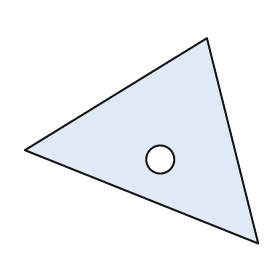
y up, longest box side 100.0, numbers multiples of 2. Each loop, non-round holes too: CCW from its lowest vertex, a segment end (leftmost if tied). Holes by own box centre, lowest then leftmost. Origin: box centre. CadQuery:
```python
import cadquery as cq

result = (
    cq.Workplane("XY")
    .moveTo(50.0, -44.0)
    .lineTo(28.0, 44.0)
    .lineTo(-50.0, -4.0)
    .close()
    .moveTo(8.0, -8.0)
    .circle(6.0)
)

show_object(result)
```